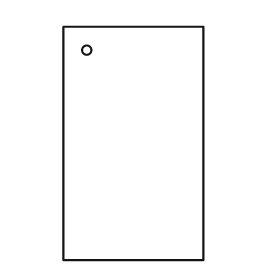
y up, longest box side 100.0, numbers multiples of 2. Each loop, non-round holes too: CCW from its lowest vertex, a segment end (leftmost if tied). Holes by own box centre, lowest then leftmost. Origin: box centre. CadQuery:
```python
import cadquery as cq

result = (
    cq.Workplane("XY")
    .moveTo(-30.0, -50.0)
    .lineTo(30.0, -50.0)
    .lineTo(30.0, 50.0)
    .lineTo(-30.0, 50.0)
    .close()
    .moveTo(-20.0, 40.0)
    .circle(2.0)
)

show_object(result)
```